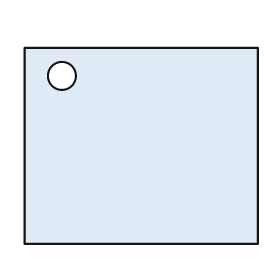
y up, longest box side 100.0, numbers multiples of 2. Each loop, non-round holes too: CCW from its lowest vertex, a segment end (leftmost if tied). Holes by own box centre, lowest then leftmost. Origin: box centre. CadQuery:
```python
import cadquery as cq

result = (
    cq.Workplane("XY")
    .moveTo(-50.0, -42.0)
    .lineTo(50.0, -42.0)
    .lineTo(50.0, 42.0)
    .lineTo(-50.0, 42.0)
    .close()
    .moveTo(-34.0, 30.0)
    .circle(6.0)
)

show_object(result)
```